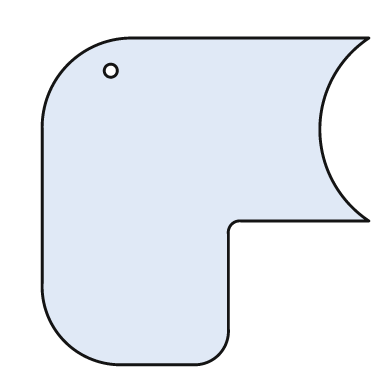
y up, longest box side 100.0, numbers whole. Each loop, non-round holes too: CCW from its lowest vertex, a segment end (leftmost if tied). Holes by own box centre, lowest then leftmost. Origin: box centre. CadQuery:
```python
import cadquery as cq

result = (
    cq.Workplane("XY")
    .moveTo(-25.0, -50.0)
    .lineTo(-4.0, -50.0)
    .threePointArc((4.0, -47.0), (7.0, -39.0))
    .lineTo(7.0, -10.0)
    .threePointArc((8.0, -7.0), (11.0, -6.0))
    .lineTo(50.0, -6.0)
    .threePointArc((35.0, 22.0), (50.0, 50.0))
    .lineTo(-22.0, 50.0)
    .threePointArc((-42.0, 42.0), (-50.0, 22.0))
    .lineTo(-50.0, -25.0)
    .threePointArc((-43.0, -43.0), (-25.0, -50.0))
    .close()
    .moveTo(-29.0, 40.0)
    .circle(2.0)
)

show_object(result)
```